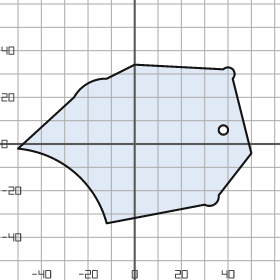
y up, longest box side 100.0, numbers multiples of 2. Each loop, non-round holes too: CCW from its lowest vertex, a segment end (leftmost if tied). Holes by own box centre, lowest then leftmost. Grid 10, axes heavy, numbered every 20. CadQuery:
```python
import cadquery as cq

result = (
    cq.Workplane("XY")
    .moveTo(-12.0, -34.0)
    .lineTo(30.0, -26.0)
    .threePointArc((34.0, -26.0), (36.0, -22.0))
    .lineTo(50.0, -4.0)
    .lineTo(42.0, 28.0)
    .threePointArc((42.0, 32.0), (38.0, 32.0))
    .lineTo(0.0, 34.0)
    .lineTo(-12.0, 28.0)
    .threePointArc((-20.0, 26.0), (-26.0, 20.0))
    .lineTo(-50.0, -2.0)
    .threePointArc((-26.0, -12.0), (-12.0, -34.0))
    .close()
    .moveTo(38.0, 6.0)
    .circle(2.0)
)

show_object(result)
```